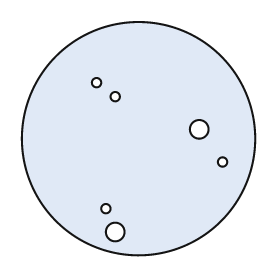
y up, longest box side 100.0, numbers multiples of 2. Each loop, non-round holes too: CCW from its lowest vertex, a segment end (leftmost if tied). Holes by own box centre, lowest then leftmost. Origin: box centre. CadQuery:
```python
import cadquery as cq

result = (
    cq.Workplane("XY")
    .moveTo(0.0, 0.0)
    .circle(50.0)
    .moveTo(-10.0, -40.0)
    .circle(4.0)
    .moveTo(-14.0, -30.0)
    .circle(2.0)
    .moveTo(36.0, -10.0)
    .circle(2.0)
    .moveTo(26.0, 4.0)
    .circle(4.0)
    .moveTo(-10.0, 18.0)
    .circle(2.0)
    .moveTo(-18.0, 24.0)
    .circle(2.0)
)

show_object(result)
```